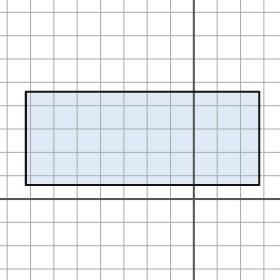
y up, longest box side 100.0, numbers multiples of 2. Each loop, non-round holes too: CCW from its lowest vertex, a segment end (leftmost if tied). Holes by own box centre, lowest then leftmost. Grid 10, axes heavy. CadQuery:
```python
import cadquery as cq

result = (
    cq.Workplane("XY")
    .moveTo(-72.0, 6.0)
    .lineTo(28.0, 6.0)
    .lineTo(28.0, 46.0)
    .lineTo(-72.0, 46.0)
    .close()
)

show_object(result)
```